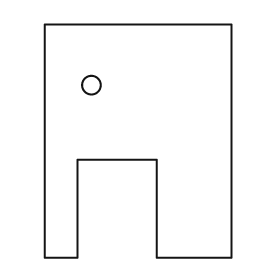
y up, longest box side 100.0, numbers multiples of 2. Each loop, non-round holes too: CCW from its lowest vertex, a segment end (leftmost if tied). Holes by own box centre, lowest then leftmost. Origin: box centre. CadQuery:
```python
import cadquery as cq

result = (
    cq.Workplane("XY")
    .moveTo(-40.0, -50.0)
    .lineTo(-26.0, -50.0)
    .lineTo(-26.0, -8.0)
    .lineTo(8.0, -8.0)
    .lineTo(8.0, -50.0)
    .lineTo(40.0, -50.0)
    .lineTo(40.0, 50.0)
    .lineTo(-40.0, 50.0)
    .close()
    .moveTo(-20.0, 24.0)
    .circle(4.0)
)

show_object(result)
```